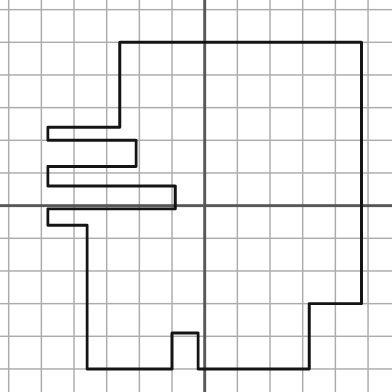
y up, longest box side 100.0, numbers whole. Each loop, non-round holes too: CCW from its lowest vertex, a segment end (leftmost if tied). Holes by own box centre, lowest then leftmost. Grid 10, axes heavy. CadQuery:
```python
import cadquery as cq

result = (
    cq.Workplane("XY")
    .moveTo(-36.0, -50.0)
    .lineTo(-10.0, -50.0)
    .lineTo(-10.0, -39.0)
    .lineTo(-2.0, -39.0)
    .lineTo(-2.0, -50.0)
    .lineTo(32.0, -50.0)
    .lineTo(32.0, -30.0)
    .lineTo(48.0, -30.0)
    .lineTo(48.0, 50.0)
    .lineTo(-26.0, 50.0)
    .lineTo(-26.0, 24.0)
    .lineTo(-48.0, 24.0)
    .lineTo(-48.0, 20.0)
    .lineTo(-21.0, 20.0)
    .lineTo(-21.0, 12.0)
    .lineTo(-48.0, 12.0)
    .lineTo(-48.0, 6.0)
    .lineTo(-9.0, 6.0)
    .lineTo(-9.0, -1.0)
    .lineTo(-48.0, -1.0)
    .lineTo(-48.0, -6.0)
    .lineTo(-36.0, -6.0)
    .close()
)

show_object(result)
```